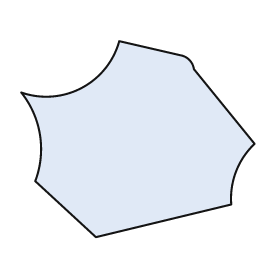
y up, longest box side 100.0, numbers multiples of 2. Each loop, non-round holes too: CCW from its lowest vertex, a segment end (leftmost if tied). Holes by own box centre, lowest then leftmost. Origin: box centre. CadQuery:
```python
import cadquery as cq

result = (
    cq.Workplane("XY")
    .moveTo(-18.0, -42.0)
    .lineTo(40.0, -28.0)
    .threePointArc((42.0, -14.0), (50.0, -2.0))
    .lineTo(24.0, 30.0)
    .threePointArc((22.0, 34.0), (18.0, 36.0))
    .lineTo(-8.0, 42.0)
    .threePointArc((-24.0, 22.0), (-50.0, 20.0))
    .threePointArc((-42.0, 2.0), (-44.0, -18.0))
    .close()
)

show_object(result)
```